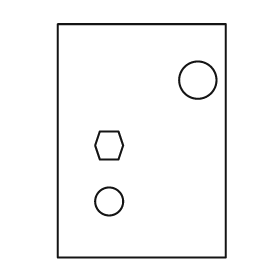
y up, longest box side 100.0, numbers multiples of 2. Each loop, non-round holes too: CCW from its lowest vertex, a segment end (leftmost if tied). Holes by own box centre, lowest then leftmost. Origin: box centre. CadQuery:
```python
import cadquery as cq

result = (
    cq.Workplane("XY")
    .moveTo(-36.0, -50.0)
    .lineTo(36.0, -50.0)
    .lineTo(36.0, 50.0)
    .lineTo(-36.0, 50.0)
    .close()
    .moveTo(-14.0, -26.0)
    .circle(6.0)
    .moveTo(-18.0, -8.0)
    .lineTo(-10.0, -8.0)
    .lineTo(-8.0, -2.0)
    .lineTo(-10.0, 4.0)
    .lineTo(-18.0, 4.0)
    .lineTo(-20.0, -2.0)
    .close()
    .moveTo(24.0, 26.0)
    .circle(8.0)
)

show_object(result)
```